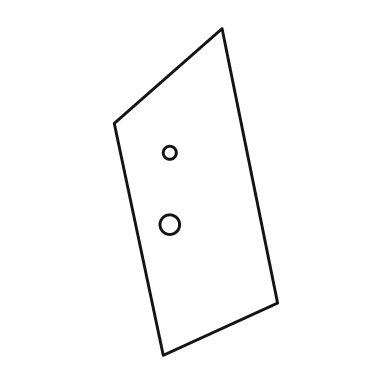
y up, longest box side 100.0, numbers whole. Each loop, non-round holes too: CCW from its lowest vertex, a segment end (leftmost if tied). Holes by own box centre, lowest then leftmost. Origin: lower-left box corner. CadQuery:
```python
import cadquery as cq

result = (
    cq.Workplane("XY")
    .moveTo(15.0, 0.0)
    .lineTo(50.0, 16.0)
    .lineTo(33.0, 100.0)
    .lineTo(0.0, 71.0)
    .close()
    .moveTo(17.0, 40.0)
    .circle(3.0)
    .moveTo(17.0, 62.0)
    .circle(2.0)
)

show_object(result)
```